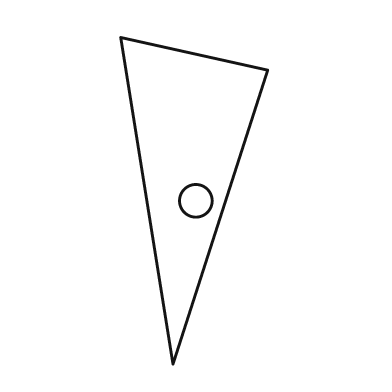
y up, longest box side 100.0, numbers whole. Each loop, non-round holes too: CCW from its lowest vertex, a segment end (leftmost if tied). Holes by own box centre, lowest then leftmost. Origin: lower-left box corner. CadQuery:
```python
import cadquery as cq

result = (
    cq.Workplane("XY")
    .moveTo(16.0, 0.0)
    .lineTo(45.0, 90.0)
    .lineTo(0.0, 100.0)
    .close()
    .moveTo(23.0, 50.0)
    .circle(5.0)
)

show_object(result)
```